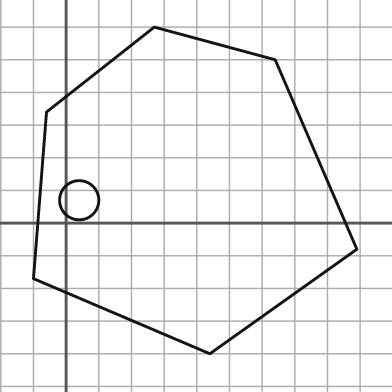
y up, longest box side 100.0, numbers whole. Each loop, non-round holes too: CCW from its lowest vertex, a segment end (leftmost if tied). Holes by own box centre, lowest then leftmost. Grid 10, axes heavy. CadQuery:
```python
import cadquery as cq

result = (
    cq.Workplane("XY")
    .moveTo(44.0, -40.0)
    .lineTo(89.0, -8.0)
    .lineTo(64.0, 50.0)
    .lineTo(27.0, 60.0)
    .lineTo(-6.0, 34.0)
    .lineTo(-10.0, -17.0)
    .close()
    .moveTo(4.0, 7.0)
    .circle(6.0)
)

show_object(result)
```